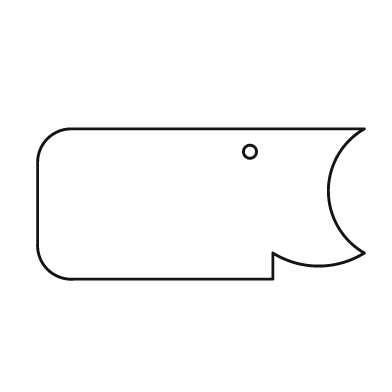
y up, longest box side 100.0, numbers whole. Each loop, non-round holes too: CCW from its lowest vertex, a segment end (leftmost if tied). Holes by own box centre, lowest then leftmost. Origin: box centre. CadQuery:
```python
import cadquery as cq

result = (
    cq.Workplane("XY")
    .moveTo(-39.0, -23.0)
    .lineTo(22.0, -23.0)
    .lineTo(22.0, -15.0)
    .threePointArc((36.0, -19.0), (50.0, -15.0))
    .threePointArc((39.0, 4.0), (50.0, 23.0))
    .lineTo(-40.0, 23.0)
    .threePointArc((-47.0, 20.0), (-50.0, 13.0))
    .lineTo(-50.0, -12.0)
    .threePointArc((-47.0, -20.0), (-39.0, -23.0))
    .close()
    .moveTo(15.0, 16.0)
    .circle(2.0)
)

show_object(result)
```